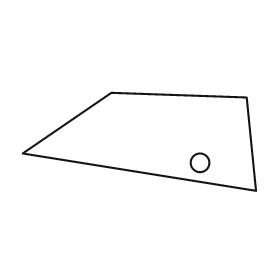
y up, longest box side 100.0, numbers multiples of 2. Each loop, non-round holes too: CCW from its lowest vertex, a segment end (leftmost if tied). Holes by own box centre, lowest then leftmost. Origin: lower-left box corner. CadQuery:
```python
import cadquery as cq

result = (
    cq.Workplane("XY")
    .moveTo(100.0, 0.0)
    .lineTo(96.0, 40.0)
    .lineTo(38.0, 42.0)
    .lineTo(0.0, 16.0)
    .close()
    .moveTo(76.0, 12.0)
    .circle(4.0)
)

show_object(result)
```